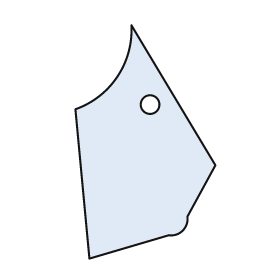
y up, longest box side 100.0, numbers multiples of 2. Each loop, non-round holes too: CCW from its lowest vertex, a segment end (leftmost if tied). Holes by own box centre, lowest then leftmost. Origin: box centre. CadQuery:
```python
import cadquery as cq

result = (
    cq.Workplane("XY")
    .moveTo(-24.0, -50.0)
    .lineTo(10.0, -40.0)
    .threePointArc((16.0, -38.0), (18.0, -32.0))
    .lineTo(30.0, -10.0)
    .lineTo(-6.0, 50.0)
    .threePointArc((-12.0, 28.0), (-30.0, 14.0))
    .close()
    .moveTo(2.0, 16.0)
    .circle(4.0)
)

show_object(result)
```